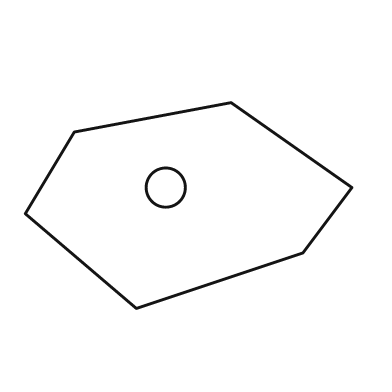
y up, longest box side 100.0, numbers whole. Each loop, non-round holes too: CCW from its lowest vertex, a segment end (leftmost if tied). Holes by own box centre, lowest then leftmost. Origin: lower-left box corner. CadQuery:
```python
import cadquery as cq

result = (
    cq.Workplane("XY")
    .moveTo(34.0, 0.0)
    .lineTo(85.0, 17.0)
    .lineTo(100.0, 37.0)
    .lineTo(63.0, 63.0)
    .lineTo(15.0, 54.0)
    .lineTo(0.0, 29.0)
    .close()
    .moveTo(43.0, 37.0)
    .circle(6.0)
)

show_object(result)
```